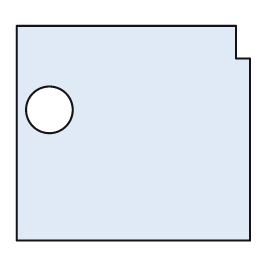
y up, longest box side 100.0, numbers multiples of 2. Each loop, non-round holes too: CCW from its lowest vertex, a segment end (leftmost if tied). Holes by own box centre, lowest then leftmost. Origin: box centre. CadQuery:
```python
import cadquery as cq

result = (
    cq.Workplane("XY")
    .moveTo(-50.0, -46.0)
    .lineTo(50.0, -46.0)
    .lineTo(50.0, 32.0)
    .lineTo(44.0, 32.0)
    .lineTo(44.0, 46.0)
    .lineTo(-50.0, 46.0)
    .close()
    .moveTo(-36.0, 10.0)
    .circle(10.0)
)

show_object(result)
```